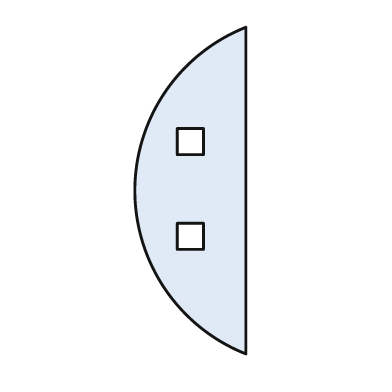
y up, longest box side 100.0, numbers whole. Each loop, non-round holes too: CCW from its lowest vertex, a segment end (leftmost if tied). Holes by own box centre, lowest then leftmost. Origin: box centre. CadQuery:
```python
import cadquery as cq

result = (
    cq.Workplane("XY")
    .moveTo(17.0, -50.0)
    .lineTo(17.0, 50.0)
    .threePointArc((-17.0, 0.0), (17.0, -50.0))
    .close()
    .moveTo(-4.0, -18.0)
    .lineTo(4.0, -18.0)
    .lineTo(4.0, -10.0)
    .lineTo(-4.0, -10.0)
    .close()
    .moveTo(-4.0, 11.0)
    .lineTo(4.0, 11.0)
    .lineTo(4.0, 19.0)
    .lineTo(-4.0, 19.0)
    .close()
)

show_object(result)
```